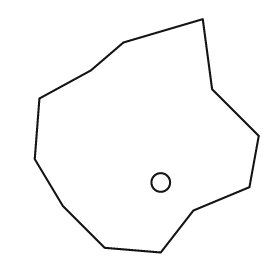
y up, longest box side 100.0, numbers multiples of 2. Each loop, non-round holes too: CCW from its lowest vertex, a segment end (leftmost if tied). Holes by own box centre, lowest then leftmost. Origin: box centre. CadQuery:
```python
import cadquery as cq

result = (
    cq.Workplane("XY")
    .moveTo(6.0, -50.0)
    .lineTo(20.0, -32.0)
    .lineTo(44.0, -22.0)
    .lineTo(48.0, 0.0)
    .lineTo(28.0, 20.0)
    .lineTo(24.0, 50.0)
    .lineTo(-10.0, 40.0)
    .lineTo(-24.0, 28.0)
    .lineTo(-46.0, 16.0)
    .lineTo(-48.0, -10.0)
    .lineTo(-36.0, -30.0)
    .lineTo(-18.0, -48.0)
    .close()
    .moveTo(6.0, -20.0)
    .circle(4.0)
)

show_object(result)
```